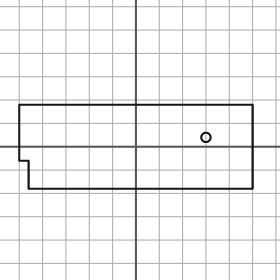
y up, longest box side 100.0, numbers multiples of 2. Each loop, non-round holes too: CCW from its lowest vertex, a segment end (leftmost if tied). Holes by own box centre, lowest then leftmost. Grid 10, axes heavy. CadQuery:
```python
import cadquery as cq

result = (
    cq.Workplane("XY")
    .moveTo(-46.0, -18.0)
    .lineTo(50.0, -18.0)
    .lineTo(50.0, 18.0)
    .lineTo(-50.0, 18.0)
    .lineTo(-50.0, -6.0)
    .lineTo(-46.0, -6.0)
    .close()
    .moveTo(30.0, 4.0)
    .circle(2.0)
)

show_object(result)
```